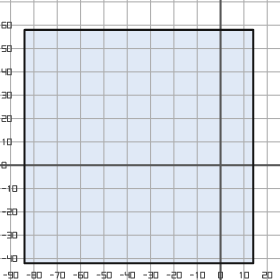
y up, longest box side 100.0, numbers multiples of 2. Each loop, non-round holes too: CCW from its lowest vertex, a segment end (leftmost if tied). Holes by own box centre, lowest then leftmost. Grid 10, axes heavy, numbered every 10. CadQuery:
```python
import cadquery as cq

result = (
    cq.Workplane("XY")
    .moveTo(-84.0, -42.0)
    .lineTo(14.0, -42.0)
    .lineTo(14.0, 58.0)
    .lineTo(-84.0, 58.0)
    .close()
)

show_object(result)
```